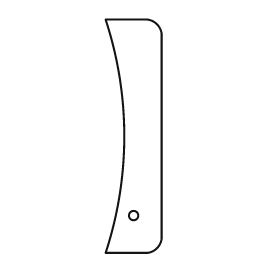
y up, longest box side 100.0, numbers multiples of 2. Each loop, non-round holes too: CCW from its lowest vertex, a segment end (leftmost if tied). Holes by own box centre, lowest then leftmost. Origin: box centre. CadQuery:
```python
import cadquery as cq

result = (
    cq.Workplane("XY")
    .moveTo(-12.0, -50.0)
    .lineTo(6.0, -50.0)
    .threePointArc((10.0, -48.0), (12.0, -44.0))
    .lineTo(12.0, 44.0)
    .threePointArc((10.0, 48.0), (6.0, 50.0))
    .lineTo(-12.0, 50.0)
    .threePointArc((-4.0, 0.0), (-12.0, -50.0))
    .close()
    .moveTo(0.0, -34.0)
    .circle(2.0)
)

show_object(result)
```